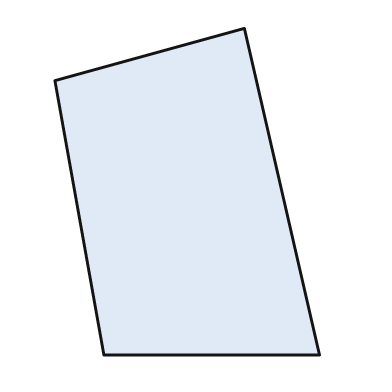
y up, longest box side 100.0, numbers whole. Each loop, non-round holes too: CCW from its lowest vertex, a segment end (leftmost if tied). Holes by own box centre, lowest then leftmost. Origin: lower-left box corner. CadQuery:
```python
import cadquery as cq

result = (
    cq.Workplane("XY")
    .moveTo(15.0, 0.0)
    .lineTo(81.0, 0.0)
    .lineTo(58.0, 100.0)
    .lineTo(0.0, 84.0)
    .close()
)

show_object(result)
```